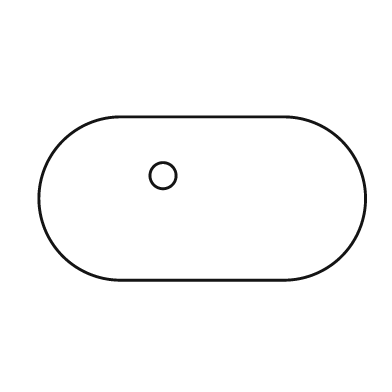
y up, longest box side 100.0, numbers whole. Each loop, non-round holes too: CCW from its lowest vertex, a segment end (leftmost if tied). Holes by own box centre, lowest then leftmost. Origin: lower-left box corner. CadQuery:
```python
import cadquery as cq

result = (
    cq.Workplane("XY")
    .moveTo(25.0, 0.0)
    .lineTo(75.0, 0.0)
    .threePointArc((100.0, 25.0), (75.0, 50.0))
    .lineTo(25.0, 50.0)
    .threePointArc((0.0, 25.0), (25.0, 0.0))
    .close()
    .moveTo(38.0, 32.0)
    .circle(4.0)
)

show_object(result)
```